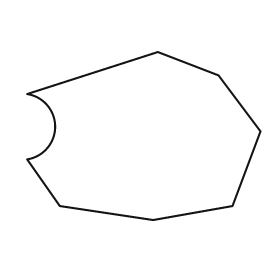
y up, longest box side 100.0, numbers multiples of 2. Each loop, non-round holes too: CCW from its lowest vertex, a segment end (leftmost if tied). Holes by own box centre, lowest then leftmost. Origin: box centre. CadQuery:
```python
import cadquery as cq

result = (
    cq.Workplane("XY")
    .moveTo(4.0, -36.0)
    .lineTo(38.0, -30.0)
    .lineTo(50.0, 2.0)
    .lineTo(32.0, 26.0)
    .lineTo(6.0, 36.0)
    .lineTo(-50.0, 18.0)
    .threePointArc((-38.0, 4.0), (-50.0, -10.0))
    .lineTo(-36.0, -30.0)
    .close()
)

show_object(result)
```